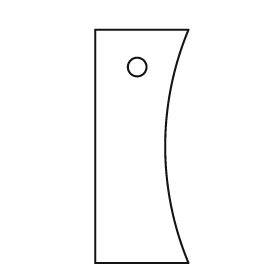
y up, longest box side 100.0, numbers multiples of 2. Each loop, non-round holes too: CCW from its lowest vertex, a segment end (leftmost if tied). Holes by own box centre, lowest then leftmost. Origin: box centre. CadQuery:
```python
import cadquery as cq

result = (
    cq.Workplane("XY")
    .moveTo(-20.0, -50.0)
    .lineTo(20.0, -50.0)
    .threePointArc((10.0, 0.0), (20.0, 50.0))
    .lineTo(-20.0, 50.0)
    .close()
    .moveTo(-2.0, 34.0)
    .circle(4.0)
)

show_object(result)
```